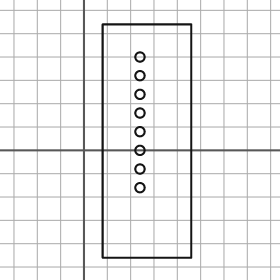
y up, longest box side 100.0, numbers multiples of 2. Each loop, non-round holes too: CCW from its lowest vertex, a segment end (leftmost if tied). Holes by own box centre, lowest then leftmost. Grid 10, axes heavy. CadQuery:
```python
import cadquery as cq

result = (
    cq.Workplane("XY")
    .moveTo(8.0, -46.0)
    .lineTo(46.0, -46.0)
    .lineTo(46.0, 54.0)
    .lineTo(8.0, 54.0)
    .close()
    .moveTo(24.0, -16.0)
    .circle(2.0)
    .moveTo(24.0, -8.0)
    .circle(2.0)
    .moveTo(24.0, 0.0)
    .circle(2.0)
    .moveTo(24.0, 8.0)
    .circle(2.0)
    .moveTo(24.0, 16.0)
    .circle(2.0)
    .moveTo(24.0, 24.0)
    .circle(2.0)
    .moveTo(24.0, 32.0)
    .circle(2.0)
    .moveTo(24.0, 40.0)
    .circle(2.0)
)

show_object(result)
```